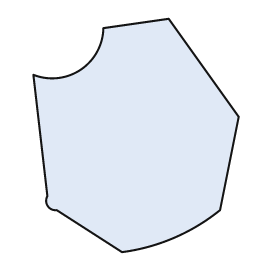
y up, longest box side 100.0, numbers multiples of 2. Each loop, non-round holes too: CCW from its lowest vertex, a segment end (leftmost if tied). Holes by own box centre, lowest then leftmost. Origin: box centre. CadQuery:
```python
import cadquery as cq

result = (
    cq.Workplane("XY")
    .moveTo(-6.0, -50.0)
    .threePointArc((16.0, -44.0), (36.0, -32.0))
    .lineTo(44.0, 8.0)
    .lineTo(14.0, 50.0)
    .lineTo(-14.0, 46.0)
    .threePointArc((-24.0, 28.0), (-44.0, 26.0))
    .lineTo(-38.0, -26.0)
    .threePointArc((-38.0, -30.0), (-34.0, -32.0))
    .close()
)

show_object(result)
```